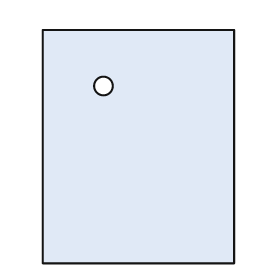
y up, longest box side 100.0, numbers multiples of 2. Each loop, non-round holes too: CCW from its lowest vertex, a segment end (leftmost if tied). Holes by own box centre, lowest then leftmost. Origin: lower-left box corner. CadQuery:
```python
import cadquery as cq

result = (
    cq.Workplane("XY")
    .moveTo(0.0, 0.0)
    .lineTo(82.0, 0.0)
    .lineTo(82.0, 100.0)
    .lineTo(0.0, 100.0)
    .close()
    .moveTo(26.0, 76.0)
    .circle(4.0)
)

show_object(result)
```